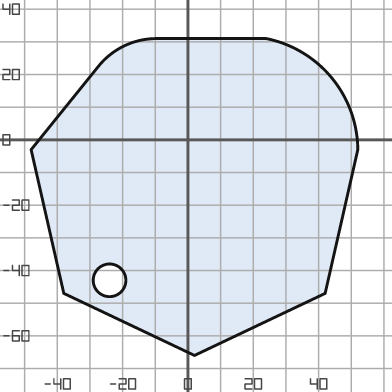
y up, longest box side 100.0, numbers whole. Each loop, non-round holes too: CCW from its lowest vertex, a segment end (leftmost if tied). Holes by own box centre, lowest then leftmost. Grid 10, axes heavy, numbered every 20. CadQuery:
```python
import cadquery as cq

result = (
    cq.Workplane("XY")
    .moveTo(2.0, -66.0)
    .lineTo(42.0, -47.0)
    .lineTo(52.0, -3.0)
    .threePointArc((44.0, 19.0), (24.0, 31.0))
    .lineTo(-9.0, 31.0)
    .threePointArc((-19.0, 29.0), (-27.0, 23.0))
    .lineTo(-48.0, -3.0)
    .lineTo(-38.0, -47.0)
    .close()
    .moveTo(-24.0, -43.0)
    .circle(5.0)
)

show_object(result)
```